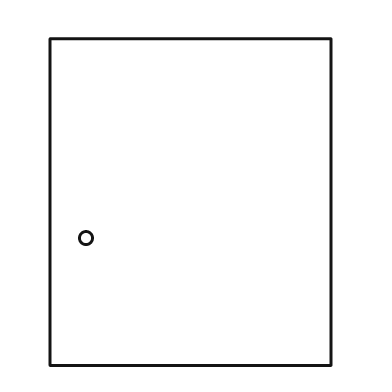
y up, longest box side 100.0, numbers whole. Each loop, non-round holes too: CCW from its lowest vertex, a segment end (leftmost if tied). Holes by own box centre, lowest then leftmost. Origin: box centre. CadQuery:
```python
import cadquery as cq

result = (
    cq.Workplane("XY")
    .moveTo(-43.0, -50.0)
    .lineTo(43.0, -50.0)
    .lineTo(43.0, 50.0)
    .lineTo(-43.0, 50.0)
    .close()
    .moveTo(-32.0, -11.0)
    .circle(2.0)
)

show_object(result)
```